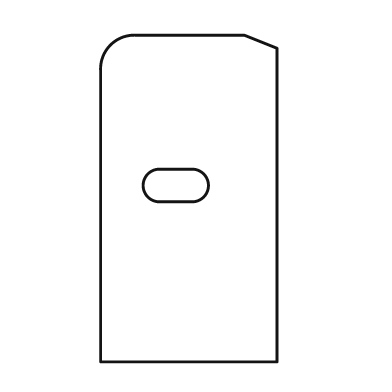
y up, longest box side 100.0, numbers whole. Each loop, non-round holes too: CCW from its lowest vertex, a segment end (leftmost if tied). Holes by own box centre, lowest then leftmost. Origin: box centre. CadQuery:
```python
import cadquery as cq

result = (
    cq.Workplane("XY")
    .moveTo(-27.0, -50.0)
    .lineTo(27.0, -50.0)
    .lineTo(27.0, 46.0)
    .lineTo(17.0, 50.0)
    .lineTo(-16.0, 50.0)
    .threePointArc((-24.0, 47.0), (-27.0, 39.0))
    .close()
    .moveTo(-9.0, -1.0)
    .lineTo(1.0, -1.0)
    .threePointArc((6.0, 4.0), (1.0, 9.0))
    .lineTo(-9.0, 9.0)
    .threePointArc((-14.0, 4.0), (-9.0, -1.0))
    .close()
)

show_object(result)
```